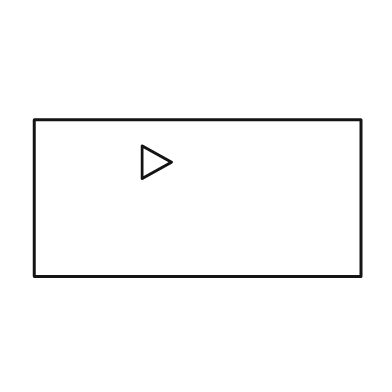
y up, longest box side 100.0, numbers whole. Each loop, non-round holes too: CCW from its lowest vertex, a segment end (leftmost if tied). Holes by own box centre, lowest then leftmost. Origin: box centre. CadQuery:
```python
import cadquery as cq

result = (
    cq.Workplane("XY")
    .moveTo(-50.0, -24.0)
    .lineTo(50.0, -24.0)
    .lineTo(50.0, 24.0)
    .lineTo(-50.0, 24.0)
    .close()
    .moveTo(-17.0, 6.0)
    .lineTo(-8.0, 11.0)
    .lineTo(-17.0, 16.0)
    .close()
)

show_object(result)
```